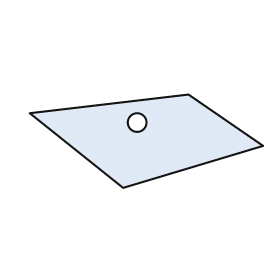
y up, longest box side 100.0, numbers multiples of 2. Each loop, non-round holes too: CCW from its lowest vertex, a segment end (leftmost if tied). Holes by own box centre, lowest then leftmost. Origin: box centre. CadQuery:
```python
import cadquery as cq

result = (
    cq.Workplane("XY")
    .moveTo(-10.0, -20.0)
    .lineTo(50.0, -2.0)
    .lineTo(18.0, 20.0)
    .lineTo(-50.0, 12.0)
    .close()
    .moveTo(-4.0, 8.0)
    .circle(4.0)
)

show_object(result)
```